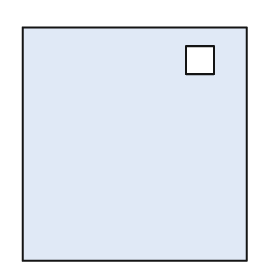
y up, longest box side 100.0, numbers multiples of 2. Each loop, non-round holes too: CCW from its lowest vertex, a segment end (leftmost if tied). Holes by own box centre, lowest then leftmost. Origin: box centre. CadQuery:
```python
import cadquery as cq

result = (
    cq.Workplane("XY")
    .moveTo(-48.0, -50.0)
    .lineTo(48.0, -50.0)
    .lineTo(48.0, 50.0)
    .lineTo(-48.0, 50.0)
    .close()
    .moveTo(22.0, 30.0)
    .lineTo(34.0, 30.0)
    .lineTo(34.0, 42.0)
    .lineTo(22.0, 42.0)
    .close()
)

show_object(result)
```